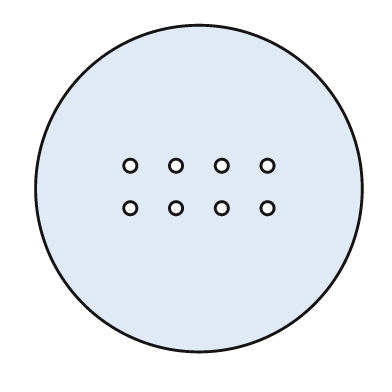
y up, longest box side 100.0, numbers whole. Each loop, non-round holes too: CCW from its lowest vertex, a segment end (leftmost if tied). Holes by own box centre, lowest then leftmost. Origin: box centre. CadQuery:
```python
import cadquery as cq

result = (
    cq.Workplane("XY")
    .moveTo(0.0, 0.0)
    .circle(50.0)
    .moveTo(-21.0, -6.0)
    .circle(2.0)
    .moveTo(-7.0, -6.0)
    .circle(2.0)
    .moveTo(7.0, -6.0)
    .circle(2.0)
    .moveTo(21.0, -6.0)
    .circle(2.0)
    .moveTo(-21.0, 7.0)
    .circle(2.0)
    .moveTo(-7.0, 7.0)
    .circle(2.0)
    .moveTo(7.0, 7.0)
    .circle(2.0)
    .moveTo(21.0, 7.0)
    .circle(2.0)
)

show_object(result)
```